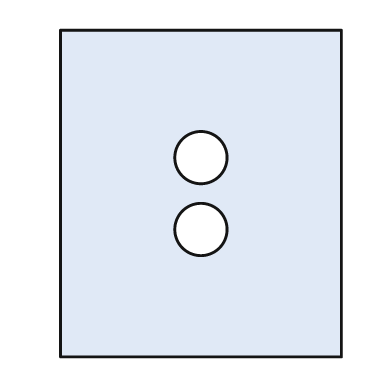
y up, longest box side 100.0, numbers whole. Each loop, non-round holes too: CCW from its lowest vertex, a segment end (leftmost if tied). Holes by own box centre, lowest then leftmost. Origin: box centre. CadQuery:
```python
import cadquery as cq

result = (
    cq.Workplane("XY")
    .moveTo(-43.0, -50.0)
    .lineTo(43.0, -50.0)
    .lineTo(43.0, 50.0)
    .lineTo(-43.0, 50.0)
    .close()
    .moveTo(0.0, -11.0)
    .circle(8.0)
    .moveTo(0.0, 11.0)
    .circle(8.0)
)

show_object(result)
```